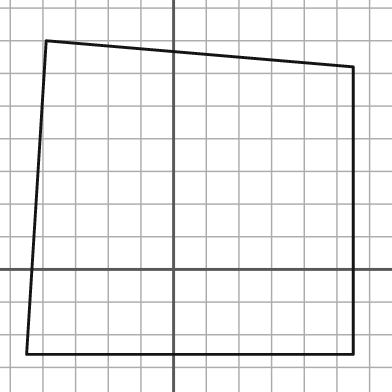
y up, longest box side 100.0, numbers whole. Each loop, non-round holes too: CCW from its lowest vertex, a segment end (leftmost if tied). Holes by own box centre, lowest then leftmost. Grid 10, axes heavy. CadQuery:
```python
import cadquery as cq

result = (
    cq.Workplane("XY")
    .moveTo(-45.0, -26.0)
    .lineTo(55.0, -26.0)
    .lineTo(55.0, 62.0)
    .lineTo(-39.0, 70.0)
    .close()
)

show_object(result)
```